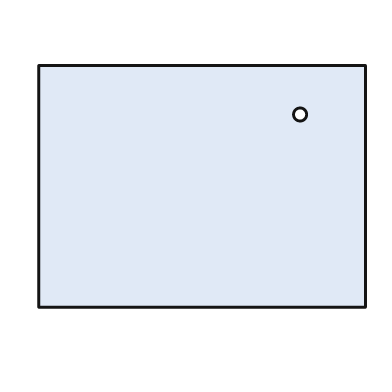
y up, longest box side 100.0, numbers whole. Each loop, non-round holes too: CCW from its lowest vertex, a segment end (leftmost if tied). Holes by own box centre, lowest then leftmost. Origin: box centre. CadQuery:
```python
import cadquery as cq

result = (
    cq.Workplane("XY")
    .moveTo(-50.0, -37.0)
    .lineTo(50.0, -37.0)
    .lineTo(50.0, 37.0)
    .lineTo(-50.0, 37.0)
    .close()
    .moveTo(30.0, 22.0)
    .circle(2.0)
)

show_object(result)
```